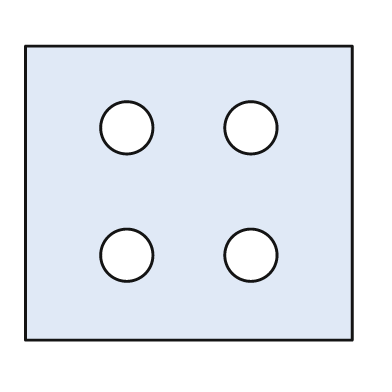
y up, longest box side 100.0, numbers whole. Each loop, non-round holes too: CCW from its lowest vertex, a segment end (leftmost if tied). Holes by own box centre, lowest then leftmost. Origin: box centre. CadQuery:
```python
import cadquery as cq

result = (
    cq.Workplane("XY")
    .moveTo(-50.0, -45.0)
    .lineTo(50.0, -45.0)
    .lineTo(50.0, 45.0)
    .lineTo(-50.0, 45.0)
    .close()
    .moveTo(-19.0, -19.0)
    .circle(8.0)
    .moveTo(19.0, -19.0)
    .circle(8.0)
    .moveTo(-19.0, 20.0)
    .circle(8.0)
    .moveTo(19.0, 20.0)
    .circle(8.0)
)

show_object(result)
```